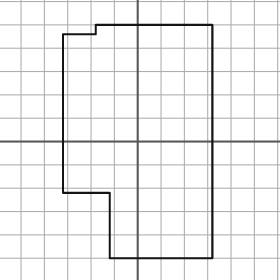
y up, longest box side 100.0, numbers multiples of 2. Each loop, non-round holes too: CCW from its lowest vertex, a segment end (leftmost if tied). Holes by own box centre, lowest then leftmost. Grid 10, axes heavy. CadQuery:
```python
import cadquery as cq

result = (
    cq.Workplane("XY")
    .moveTo(-12.0, -50.0)
    .lineTo(32.0, -50.0)
    .lineTo(32.0, 50.0)
    .lineTo(-18.0, 50.0)
    .lineTo(-18.0, 46.0)
    .lineTo(-32.0, 46.0)
    .lineTo(-32.0, -22.0)
    .lineTo(-12.0, -22.0)
    .close()
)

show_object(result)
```